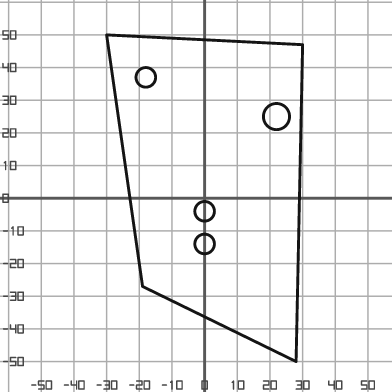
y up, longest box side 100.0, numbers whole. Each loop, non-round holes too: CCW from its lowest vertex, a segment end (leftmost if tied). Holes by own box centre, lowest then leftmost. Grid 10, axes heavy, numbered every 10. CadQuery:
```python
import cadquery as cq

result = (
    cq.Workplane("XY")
    .moveTo(28.0, -50.0)
    .lineTo(30.0, 47.0)
    .lineTo(-30.0, 50.0)
    .lineTo(-19.0, -27.0)
    .close()
    .moveTo(0.0, -14.0)
    .circle(3.0)
    .moveTo(0.0, -4.0)
    .circle(3.0)
    .moveTo(22.0, 25.0)
    .circle(4.0)
    .moveTo(-18.0, 37.0)
    .circle(3.0)
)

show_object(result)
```